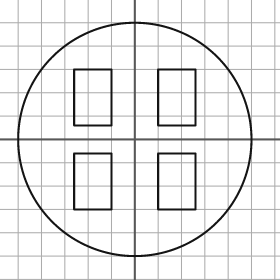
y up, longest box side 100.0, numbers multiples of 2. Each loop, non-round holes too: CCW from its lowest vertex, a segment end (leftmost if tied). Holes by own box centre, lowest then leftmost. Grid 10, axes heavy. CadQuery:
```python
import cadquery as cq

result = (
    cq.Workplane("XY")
    .moveTo(0.0, 0.0)
    .circle(50.0)
    .moveTo(-26.0, -30.0)
    .lineTo(-10.0, -30.0)
    .lineTo(-10.0, -6.0)
    .lineTo(-26.0, -6.0)
    .close()
    .moveTo(10.0, -30.0)
    .lineTo(26.0, -30.0)
    .lineTo(26.0, -6.0)
    .lineTo(10.0, -6.0)
    .close()
    .moveTo(-26.0, 6.0)
    .lineTo(-10.0, 6.0)
    .lineTo(-10.0, 30.0)
    .lineTo(-26.0, 30.0)
    .close()
    .moveTo(10.0, 6.0)
    .lineTo(26.0, 6.0)
    .lineTo(26.0, 30.0)
    .lineTo(10.0, 30.0)
    .close()
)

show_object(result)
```